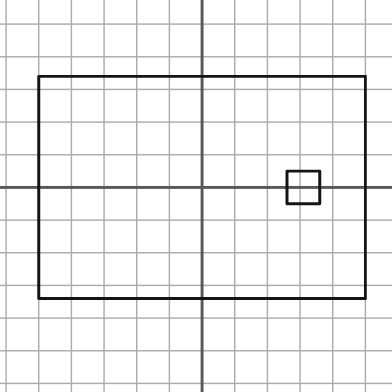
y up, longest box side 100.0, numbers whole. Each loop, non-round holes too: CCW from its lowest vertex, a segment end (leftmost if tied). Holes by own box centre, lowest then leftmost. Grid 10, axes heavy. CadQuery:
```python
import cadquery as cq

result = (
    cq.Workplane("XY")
    .moveTo(-50.0, -34.0)
    .lineTo(50.0, -34.0)
    .lineTo(50.0, 34.0)
    .lineTo(-50.0, 34.0)
    .close()
    .moveTo(26.0, -5.0)
    .lineTo(36.0, -5.0)
    .lineTo(36.0, 5.0)
    .lineTo(26.0, 5.0)
    .close()
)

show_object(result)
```